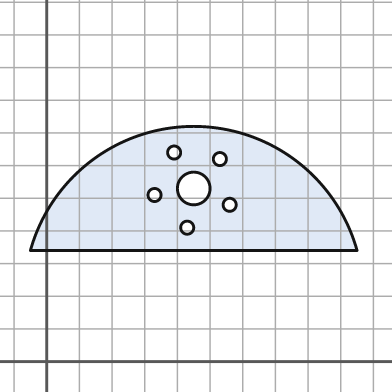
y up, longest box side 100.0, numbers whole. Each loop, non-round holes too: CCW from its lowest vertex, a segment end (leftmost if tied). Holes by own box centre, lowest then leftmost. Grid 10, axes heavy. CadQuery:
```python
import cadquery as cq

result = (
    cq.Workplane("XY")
    .moveTo(-5.0, 34.0)
    .lineTo(95.0, 34.0)
    .threePointArc((45.0, 72.0), (-5.0, 34.0))
    .close()
    .moveTo(43.0, 41.0)
    .circle(2.0)
    .moveTo(56.0, 48.0)
    .circle(2.0)
    .moveTo(33.0, 51.0)
    .circle(2.0)
    .moveTo(45.0, 53.0)
    .circle(5.0)
    .moveTo(53.0, 62.0)
    .circle(2.0)
    .moveTo(39.0, 64.0)
    .circle(2.0)
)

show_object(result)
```